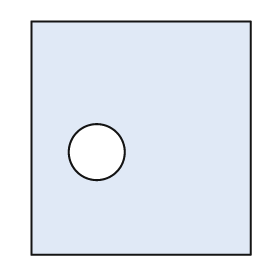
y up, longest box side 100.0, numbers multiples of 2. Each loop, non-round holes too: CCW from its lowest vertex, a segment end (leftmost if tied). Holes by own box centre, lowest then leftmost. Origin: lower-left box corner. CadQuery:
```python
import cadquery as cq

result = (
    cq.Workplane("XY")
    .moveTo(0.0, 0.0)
    .lineTo(94.0, 0.0)
    .lineTo(94.0, 100.0)
    .lineTo(0.0, 100.0)
    .close()
    .moveTo(28.0, 44.0)
    .circle(12.0)
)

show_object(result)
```